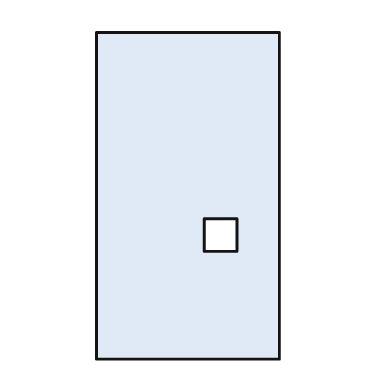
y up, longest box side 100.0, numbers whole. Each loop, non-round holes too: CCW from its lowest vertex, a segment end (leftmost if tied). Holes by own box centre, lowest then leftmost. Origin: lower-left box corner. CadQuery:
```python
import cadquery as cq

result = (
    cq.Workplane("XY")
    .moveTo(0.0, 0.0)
    .lineTo(56.0, 0.0)
    .lineTo(56.0, 100.0)
    .lineTo(0.0, 100.0)
    .close()
    .moveTo(33.0, 33.0)
    .lineTo(43.0, 33.0)
    .lineTo(43.0, 43.0)
    .lineTo(33.0, 43.0)
    .close()
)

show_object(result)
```